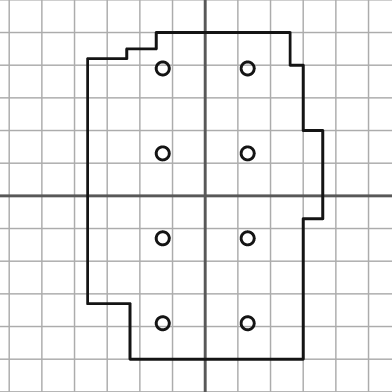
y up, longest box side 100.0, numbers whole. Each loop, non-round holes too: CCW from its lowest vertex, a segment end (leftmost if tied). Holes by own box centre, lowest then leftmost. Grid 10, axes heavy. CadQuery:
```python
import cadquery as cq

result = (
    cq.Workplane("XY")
    .moveTo(-23.0, -50.0)
    .lineTo(30.0, -50.0)
    .lineTo(30.0, -7.0)
    .lineTo(36.0, -7.0)
    .lineTo(36.0, 20.0)
    .lineTo(30.0, 20.0)
    .lineTo(30.0, 40.0)
    .lineTo(26.0, 40.0)
    .lineTo(26.0, 50.0)
    .lineTo(-15.0, 50.0)
    .lineTo(-15.0, 45.0)
    .lineTo(-24.0, 45.0)
    .lineTo(-24.0, 42.0)
    .lineTo(-36.0, 42.0)
    .lineTo(-36.0, -33.0)
    .lineTo(-23.0, -33.0)
    .close()
    .moveTo(-13.0, -39.0)
    .circle(2.0)
    .moveTo(13.0, -39.0)
    .circle(2.0)
    .moveTo(-13.0, -13.0)
    .circle(2.0)
    .moveTo(13.0, -13.0)
    .circle(2.0)
    .moveTo(-13.0, 13.0)
    .circle(2.0)
    .moveTo(13.0, 13.0)
    .circle(2.0)
    .moveTo(-13.0, 39.0)
    .circle(2.0)
    .moveTo(13.0, 39.0)
    .circle(2.0)
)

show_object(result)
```